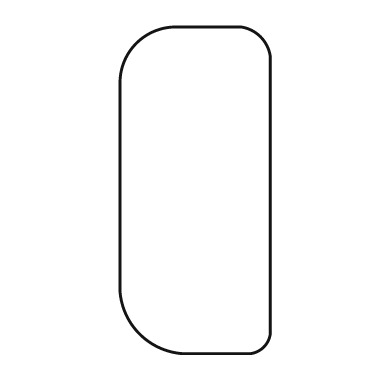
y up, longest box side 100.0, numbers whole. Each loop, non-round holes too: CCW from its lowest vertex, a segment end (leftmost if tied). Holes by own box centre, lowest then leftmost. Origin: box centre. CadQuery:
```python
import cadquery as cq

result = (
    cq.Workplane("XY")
    .moveTo(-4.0, -50.0)
    .lineTo(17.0, -50.0)
    .threePointArc((21.0, -48.0), (23.0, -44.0))
    .lineTo(23.0, 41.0)
    .threePointArc((20.0, 47.0), (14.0, 50.0))
    .lineTo(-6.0, 50.0)
    .threePointArc((-18.0, 45.0), (-23.0, 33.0))
    .lineTo(-23.0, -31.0)
    .threePointArc((-17.0, -44.0), (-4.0, -50.0))
    .close()
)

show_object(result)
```